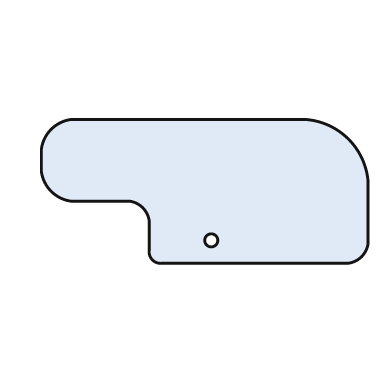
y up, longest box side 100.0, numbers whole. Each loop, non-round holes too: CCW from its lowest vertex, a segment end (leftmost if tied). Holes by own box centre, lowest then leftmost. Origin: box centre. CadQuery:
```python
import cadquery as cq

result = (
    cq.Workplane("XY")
    .moveTo(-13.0, -22.0)
    .lineTo(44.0, -22.0)
    .threePointArc((48.0, -20.0), (50.0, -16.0))
    .lineTo(50.0, 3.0)
    .threePointArc((44.0, 16.0), (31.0, 22.0))
    .lineTo(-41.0, 22.0)
    .threePointArc((-47.0, 19.0), (-50.0, 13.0))
    .lineTo(-50.0, 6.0)
    .threePointArc((-47.0, 0.0), (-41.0, -3.0))
    .lineTo(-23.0, -3.0)
    .threePointArc((-19.0, -5.0), (-17.0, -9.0))
    .lineTo(-17.0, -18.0)
    .threePointArc((-16.0, -21.0), (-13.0, -22.0))
    .close()
    .moveTo(2.0, -15.0)
    .circle(2.0)
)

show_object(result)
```